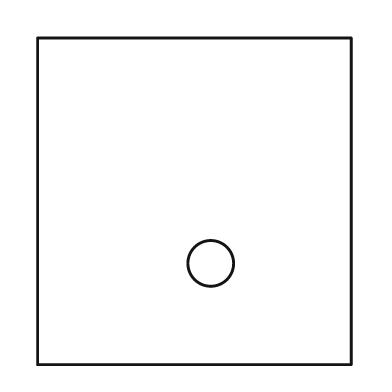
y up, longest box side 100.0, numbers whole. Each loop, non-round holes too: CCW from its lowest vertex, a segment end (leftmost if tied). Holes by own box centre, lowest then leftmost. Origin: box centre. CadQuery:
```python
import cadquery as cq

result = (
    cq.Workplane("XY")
    .moveTo(-48.0, -50.0)
    .lineTo(48.0, -50.0)
    .lineTo(48.0, 50.0)
    .lineTo(-48.0, 50.0)
    .close()
    .moveTo(5.0, -19.0)
    .circle(7.0)
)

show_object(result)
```